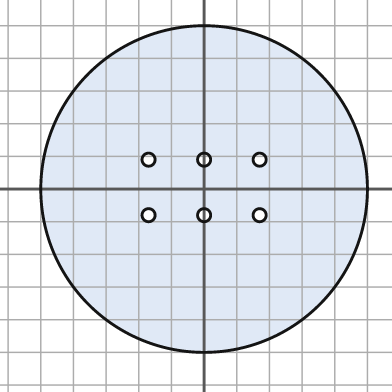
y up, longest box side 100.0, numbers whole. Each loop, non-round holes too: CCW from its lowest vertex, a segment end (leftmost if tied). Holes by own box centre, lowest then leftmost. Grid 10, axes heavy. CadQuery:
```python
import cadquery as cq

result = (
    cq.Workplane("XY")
    .moveTo(0.0, 0.0)
    .circle(50.0)
    .moveTo(-17.0, -8.0)
    .circle(2.0)
    .moveTo(0.0, -8.0)
    .circle(2.0)
    .moveTo(17.0, -8.0)
    .circle(2.0)
    .moveTo(-17.0, 9.0)
    .circle(2.0)
    .moveTo(0.0, 9.0)
    .circle(2.0)
    .moveTo(17.0, 9.0)
    .circle(2.0)
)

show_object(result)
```